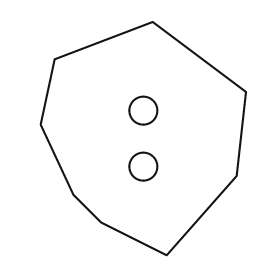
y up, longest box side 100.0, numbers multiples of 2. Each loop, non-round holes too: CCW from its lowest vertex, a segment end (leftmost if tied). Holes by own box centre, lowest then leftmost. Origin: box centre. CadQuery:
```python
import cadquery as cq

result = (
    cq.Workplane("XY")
    .moveTo(10.0, -50.0)
    .lineTo(40.0, -16.0)
    .lineTo(44.0, 20.0)
    .lineTo(4.0, 50.0)
    .lineTo(-38.0, 34.0)
    .lineTo(-44.0, 6.0)
    .lineTo(-30.0, -24.0)
    .lineTo(-18.0, -36.0)
    .close()
    .moveTo(0.0, -12.0)
    .circle(6.0)
    .moveTo(0.0, 12.0)
    .circle(6.0)
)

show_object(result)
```